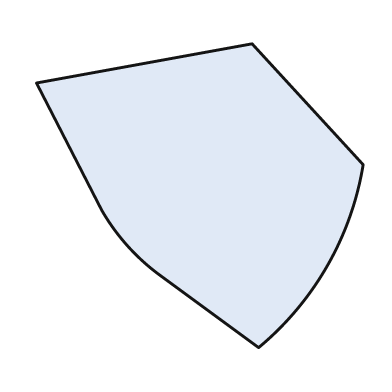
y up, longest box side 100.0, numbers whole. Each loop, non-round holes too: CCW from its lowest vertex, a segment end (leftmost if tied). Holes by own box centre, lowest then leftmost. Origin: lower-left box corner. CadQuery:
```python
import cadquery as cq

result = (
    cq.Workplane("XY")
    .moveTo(68.0, 0.0)
    .threePointArc((89.0, 25.0), (100.0, 56.0))
    .lineTo(66.0, 93.0)
    .lineTo(0.0, 81.0)
    .lineTo(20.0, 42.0)
    .threePointArc((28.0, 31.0), (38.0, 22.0))
    .close()
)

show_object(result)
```